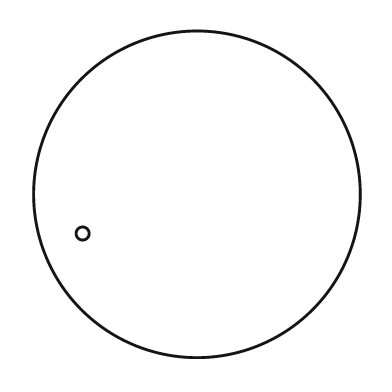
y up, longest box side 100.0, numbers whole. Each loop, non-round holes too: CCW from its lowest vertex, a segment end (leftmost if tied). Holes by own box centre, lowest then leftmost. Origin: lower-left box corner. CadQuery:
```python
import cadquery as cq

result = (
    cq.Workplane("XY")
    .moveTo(50.0, 50.0)
    .circle(50.0)
    .moveTo(15.0, 38.0)
    .circle(2.0)
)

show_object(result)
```